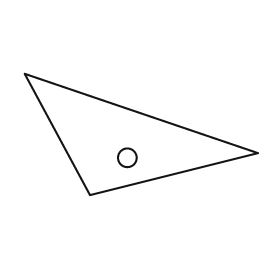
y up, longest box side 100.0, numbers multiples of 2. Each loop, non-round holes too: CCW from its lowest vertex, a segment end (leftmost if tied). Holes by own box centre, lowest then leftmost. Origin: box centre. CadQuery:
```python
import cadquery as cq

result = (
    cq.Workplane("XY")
    .moveTo(-22.0, -26.0)
    .lineTo(50.0, -8.0)
    .lineTo(-50.0, 26.0)
    .close()
    .moveTo(-6.0, -10.0)
    .circle(4.0)
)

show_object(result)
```